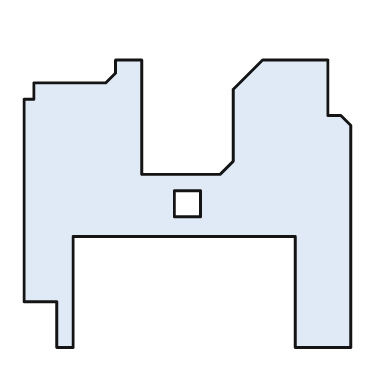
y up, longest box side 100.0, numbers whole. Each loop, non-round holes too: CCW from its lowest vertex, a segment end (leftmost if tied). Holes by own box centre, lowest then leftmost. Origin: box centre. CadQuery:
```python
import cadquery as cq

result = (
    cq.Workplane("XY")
    .moveTo(-40.0, -44.0)
    .lineTo(-35.0, -44.0)
    .lineTo(-35.0, -10.0)
    .lineTo(33.0, -10.0)
    .lineTo(33.0, -44.0)
    .lineTo(50.0, -44.0)
    .lineTo(50.0, 24.0)
    .lineTo(47.0, 27.0)
    .lineTo(43.0, 27.0)
    .lineTo(43.0, 44.0)
    .lineTo(23.0, 44.0)
    .lineTo(14.0, 35.0)
    .lineTo(14.0, 13.0)
    .lineTo(10.0, 9.0)
    .lineTo(-14.0, 9.0)
    .lineTo(-14.0, 44.0)
    .lineTo(-22.0, 44.0)
    .lineTo(-22.0, 40.0)
    .lineTo(-25.0, 37.0)
    .lineTo(-47.0, 37.0)
    .lineTo(-47.0, 32.0)
    .lineTo(-50.0, 32.0)
    .lineTo(-50.0, -30.0)
    .lineTo(-40.0, -30.0)
    .close()
    .moveTo(-4.0, -4.0)
    .lineTo(4.0, -4.0)
    .lineTo(4.0, 4.0)
    .lineTo(-4.0, 4.0)
    .close()
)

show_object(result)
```